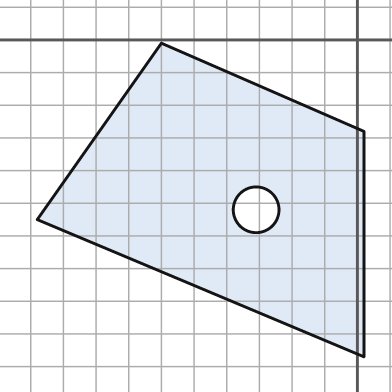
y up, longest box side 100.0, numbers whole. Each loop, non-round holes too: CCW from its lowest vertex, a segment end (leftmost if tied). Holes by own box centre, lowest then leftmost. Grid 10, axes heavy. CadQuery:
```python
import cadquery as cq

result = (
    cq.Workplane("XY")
    .moveTo(2.0, -97.0)
    .lineTo(2.0, -28.0)
    .lineTo(-60.0, -1.0)
    .lineTo(-98.0, -55.0)
    .close()
    .moveTo(-31.0, -52.0)
    .circle(7.0)
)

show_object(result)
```